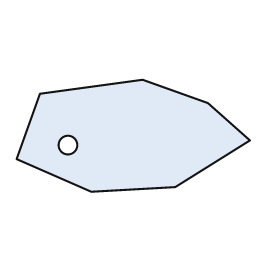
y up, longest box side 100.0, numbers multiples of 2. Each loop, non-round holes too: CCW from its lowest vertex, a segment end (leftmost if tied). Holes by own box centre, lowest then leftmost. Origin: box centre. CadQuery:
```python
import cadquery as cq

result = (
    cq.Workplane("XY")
    .moveTo(-18.0, -24.0)
    .lineTo(18.0, -22.0)
    .lineTo(50.0, -2.0)
    .lineTo(32.0, 14.0)
    .lineTo(4.0, 24.0)
    .lineTo(-40.0, 18.0)
    .lineTo(-50.0, -10.0)
    .close()
    .moveTo(-28.0, -4.0)
    .circle(4.0)
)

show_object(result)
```